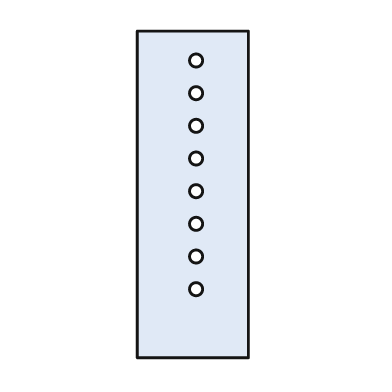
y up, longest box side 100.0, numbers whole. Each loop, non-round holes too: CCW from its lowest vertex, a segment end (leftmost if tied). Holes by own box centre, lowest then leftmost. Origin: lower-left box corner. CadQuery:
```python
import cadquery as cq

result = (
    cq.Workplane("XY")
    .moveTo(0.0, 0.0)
    .lineTo(34.0, 0.0)
    .lineTo(34.0, 100.0)
    .lineTo(0.0, 100.0)
    .close()
    .moveTo(18.0, 21.0)
    .circle(2.0)
    .moveTo(18.0, 31.0)
    .circle(2.0)
    .moveTo(18.0, 41.0)
    .circle(2.0)
    .moveTo(18.0, 51.0)
    .circle(2.0)
    .moveTo(18.0, 61.0)
    .circle(2.0)
    .moveTo(18.0, 71.0)
    .circle(2.0)
    .moveTo(18.0, 81.0)
    .circle(2.0)
    .moveTo(18.0, 91.0)
    .circle(2.0)
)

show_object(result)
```